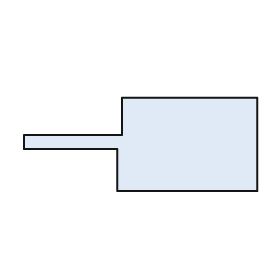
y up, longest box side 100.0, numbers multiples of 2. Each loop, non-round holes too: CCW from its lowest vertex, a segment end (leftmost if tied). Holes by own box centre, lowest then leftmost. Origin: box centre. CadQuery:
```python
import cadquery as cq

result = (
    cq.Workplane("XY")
    .moveTo(-10.0, -20.0)
    .lineTo(50.0, -20.0)
    .lineTo(50.0, 20.0)
    .lineTo(-8.0, 20.0)
    .lineTo(-8.0, 4.0)
    .lineTo(-50.0, 4.0)
    .lineTo(-50.0, -2.0)
    .lineTo(-10.0, -2.0)
    .close()
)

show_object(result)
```